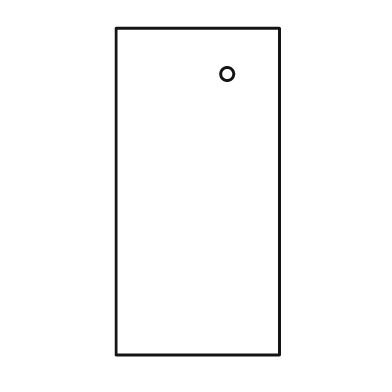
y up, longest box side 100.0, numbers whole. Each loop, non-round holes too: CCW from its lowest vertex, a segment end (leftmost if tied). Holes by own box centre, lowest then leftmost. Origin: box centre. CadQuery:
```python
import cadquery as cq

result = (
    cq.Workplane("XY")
    .moveTo(-25.0, -50.0)
    .lineTo(25.0, -50.0)
    .lineTo(25.0, 50.0)
    .lineTo(-25.0, 50.0)
    .close()
    .moveTo(9.0, 36.0)
    .circle(2.0)
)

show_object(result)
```